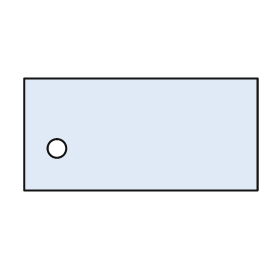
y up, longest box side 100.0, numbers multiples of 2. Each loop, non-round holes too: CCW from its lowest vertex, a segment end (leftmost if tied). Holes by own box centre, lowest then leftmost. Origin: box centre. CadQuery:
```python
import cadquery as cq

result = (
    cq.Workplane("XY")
    .moveTo(-50.0, -24.0)
    .lineTo(50.0, -24.0)
    .lineTo(50.0, 24.0)
    .lineTo(-50.0, 24.0)
    .close()
    .moveTo(-36.0, -6.0)
    .circle(4.0)
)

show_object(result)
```